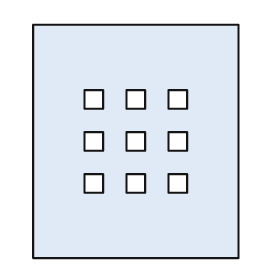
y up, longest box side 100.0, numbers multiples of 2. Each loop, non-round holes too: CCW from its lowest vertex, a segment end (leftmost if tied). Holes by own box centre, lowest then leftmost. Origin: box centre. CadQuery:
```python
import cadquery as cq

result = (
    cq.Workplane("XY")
    .moveTo(-44.0, -50.0)
    .lineTo(44.0, -50.0)
    .lineTo(44.0, 50.0)
    .lineTo(-44.0, 50.0)
    .close()
    .moveTo(-22.0, -22.0)
    .lineTo(-14.0, -22.0)
    .lineTo(-14.0, -14.0)
    .lineTo(-22.0, -14.0)
    .close()
    .moveTo(-4.0, -22.0)
    .lineTo(4.0, -22.0)
    .lineTo(4.0, -14.0)
    .lineTo(-4.0, -14.0)
    .close()
    .moveTo(14.0, -22.0)
    .lineTo(22.0, -22.0)
    .lineTo(22.0, -14.0)
    .lineTo(14.0, -14.0)
    .close()
    .moveTo(-22.0, -4.0)
    .lineTo(-14.0, -4.0)
    .lineTo(-14.0, 4.0)
    .lineTo(-22.0, 4.0)
    .close()
    .moveTo(-4.0, -4.0)
    .lineTo(4.0, -4.0)
    .lineTo(4.0, 4.0)
    .lineTo(-4.0, 4.0)
    .close()
    .moveTo(14.0, -4.0)
    .lineTo(22.0, -4.0)
    .lineTo(22.0, 4.0)
    .lineTo(14.0, 4.0)
    .close()
    .moveTo(-22.0, 14.0)
    .lineTo(-14.0, 14.0)
    .lineTo(-14.0, 22.0)
    .lineTo(-22.0, 22.0)
    .close()
    .moveTo(-4.0, 14.0)
    .lineTo(4.0, 14.0)
    .lineTo(4.0, 22.0)
    .lineTo(-4.0, 22.0)
    .close()
    .moveTo(14.0, 14.0)
    .lineTo(22.0, 14.0)
    .lineTo(22.0, 22.0)
    .lineTo(14.0, 22.0)
    .close()
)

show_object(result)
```